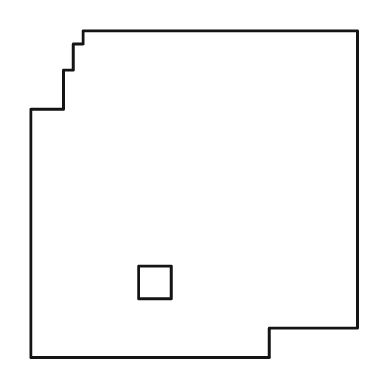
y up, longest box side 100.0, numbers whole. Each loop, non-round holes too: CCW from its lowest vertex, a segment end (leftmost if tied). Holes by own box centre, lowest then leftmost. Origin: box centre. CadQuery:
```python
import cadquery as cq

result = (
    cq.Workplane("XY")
    .moveTo(-50.0, -50.0)
    .lineTo(23.0, -50.0)
    .lineTo(23.0, -41.0)
    .lineTo(50.0, -41.0)
    .lineTo(50.0, 50.0)
    .lineTo(-34.0, 50.0)
    .lineTo(-34.0, 46.0)
    .lineTo(-37.0, 46.0)
    .lineTo(-37.0, 38.0)
    .lineTo(-40.0, 38.0)
    .lineTo(-40.0, 26.0)
    .lineTo(-50.0, 26.0)
    .close()
    .moveTo(-17.0, -32.0)
    .lineTo(-7.0, -32.0)
    .lineTo(-7.0, -22.0)
    .lineTo(-17.0, -22.0)
    .close()
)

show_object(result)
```